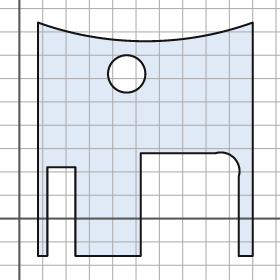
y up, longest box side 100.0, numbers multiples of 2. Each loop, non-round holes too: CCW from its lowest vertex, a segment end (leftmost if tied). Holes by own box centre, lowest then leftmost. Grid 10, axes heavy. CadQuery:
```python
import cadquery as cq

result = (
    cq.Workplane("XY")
    .moveTo(8.0, -16.0)
    .lineTo(12.0, -16.0)
    .lineTo(12.0, 22.0)
    .lineTo(24.0, 22.0)
    .lineTo(24.0, -16.0)
    .lineTo(52.0, -16.0)
    .lineTo(52.0, 28.0)
    .lineTo(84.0, 28.0)
    .threePointArc((92.0, 26.0), (94.0, 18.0))
    .lineTo(94.0, -16.0)
    .lineTo(100.0, -16.0)
    .lineTo(100.0, 84.0)
    .threePointArc((54.0, 76.0), (8.0, 84.0))
    .close()
    .moveTo(46.0, 62.0)
    .circle(8.0)
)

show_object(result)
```